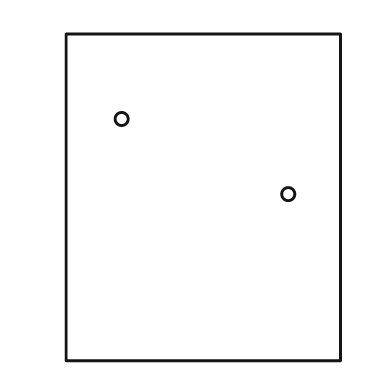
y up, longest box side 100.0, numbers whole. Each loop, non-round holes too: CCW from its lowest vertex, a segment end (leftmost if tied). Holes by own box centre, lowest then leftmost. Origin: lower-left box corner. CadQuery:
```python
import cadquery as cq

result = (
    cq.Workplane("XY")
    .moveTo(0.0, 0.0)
    .lineTo(84.0, 0.0)
    .lineTo(84.0, 100.0)
    .lineTo(0.0, 100.0)
    .close()
    .moveTo(68.0, 51.0)
    .circle(2.0)
    .moveTo(17.0, 74.0)
    .circle(2.0)
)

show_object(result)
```